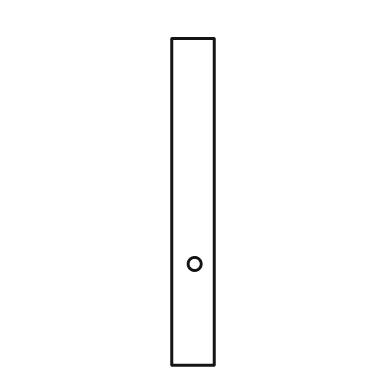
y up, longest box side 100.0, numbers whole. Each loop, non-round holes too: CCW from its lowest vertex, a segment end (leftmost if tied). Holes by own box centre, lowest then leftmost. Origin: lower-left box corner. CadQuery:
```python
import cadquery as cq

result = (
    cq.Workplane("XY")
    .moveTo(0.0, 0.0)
    .lineTo(13.0, 0.0)
    .lineTo(13.0, 100.0)
    .lineTo(0.0, 100.0)
    .close()
    .moveTo(7.0, 31.0)
    .circle(2.0)
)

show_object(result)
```